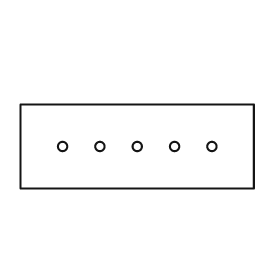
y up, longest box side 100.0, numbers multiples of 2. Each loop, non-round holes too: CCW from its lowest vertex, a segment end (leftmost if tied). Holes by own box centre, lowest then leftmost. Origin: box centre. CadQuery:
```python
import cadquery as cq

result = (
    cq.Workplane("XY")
    .moveTo(-50.0, -18.0)
    .lineTo(50.0, -18.0)
    .lineTo(50.0, 18.0)
    .lineTo(-50.0, 18.0)
    .close()
    .moveTo(-32.0, 0.0)
    .circle(2.0)
    .moveTo(-16.0, 0.0)
    .circle(2.0)
    .moveTo(0.0, 0.0)
    .circle(2.0)
    .moveTo(16.0, 0.0)
    .circle(2.0)
    .moveTo(32.0, 0.0)
    .circle(2.0)
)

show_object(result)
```